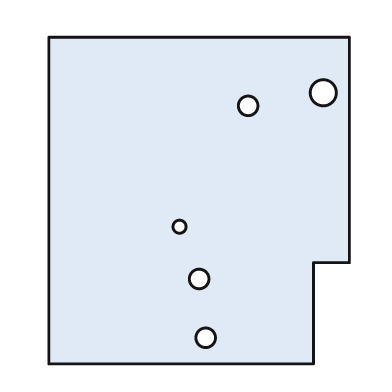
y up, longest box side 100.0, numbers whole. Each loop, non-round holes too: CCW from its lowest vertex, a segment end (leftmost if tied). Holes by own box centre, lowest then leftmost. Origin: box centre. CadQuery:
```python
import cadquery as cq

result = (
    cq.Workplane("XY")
    .moveTo(-46.0, -50.0)
    .lineTo(35.0, -50.0)
    .lineTo(35.0, -19.0)
    .lineTo(46.0, -19.0)
    .lineTo(46.0, 50.0)
    .lineTo(-46.0, 50.0)
    .close()
    .moveTo(2.0, -42.0)
    .circle(3.0)
    .moveTo(0.0, -24.0)
    .circle(3.0)
    .moveTo(-6.0, -8.0)
    .circle(2.0)
    .moveTo(15.0, 29.0)
    .circle(3.0)
    .moveTo(38.0, 33.0)
    .circle(4.0)
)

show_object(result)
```